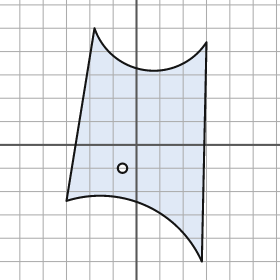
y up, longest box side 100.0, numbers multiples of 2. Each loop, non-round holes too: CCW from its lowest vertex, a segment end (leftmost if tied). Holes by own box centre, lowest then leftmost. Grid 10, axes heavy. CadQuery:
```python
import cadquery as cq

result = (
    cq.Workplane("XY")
    .moveTo(28.0, -50.0)
    .lineTo(30.0, 44.0)
    .threePointArc((4.0, 32.0), (-18.0, 50.0))
    .lineTo(-30.0, -24.0)
    .threePointArc((4.0, -26.0), (28.0, -50.0))
    .close()
    .moveTo(-6.0, -10.0)
    .circle(2.0)
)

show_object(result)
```